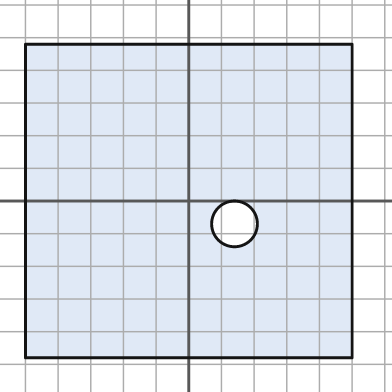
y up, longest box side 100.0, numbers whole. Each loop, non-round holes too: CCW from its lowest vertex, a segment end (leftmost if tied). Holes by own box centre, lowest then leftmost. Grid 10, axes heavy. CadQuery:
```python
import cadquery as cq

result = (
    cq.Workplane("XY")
    .moveTo(-50.0, -48.0)
    .lineTo(50.0, -48.0)
    .lineTo(50.0, 48.0)
    .lineTo(-50.0, 48.0)
    .close()
    .moveTo(14.0, -7.0)
    .circle(7.0)
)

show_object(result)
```